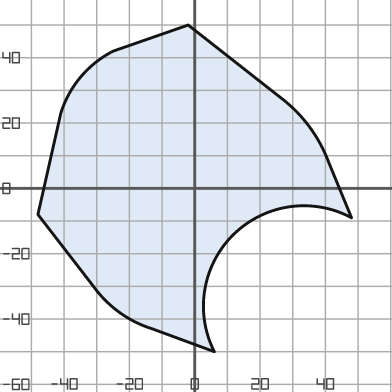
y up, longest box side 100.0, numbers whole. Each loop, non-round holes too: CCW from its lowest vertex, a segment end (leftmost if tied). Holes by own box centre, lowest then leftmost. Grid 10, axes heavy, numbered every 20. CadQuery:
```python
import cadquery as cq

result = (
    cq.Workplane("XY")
    .moveTo(6.0, -50.0)
    .threePointArc((12.0, -14.0), (48.0, -9.0))
    .lineTo(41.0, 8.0)
    .threePointArc((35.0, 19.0), (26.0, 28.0))
    .lineTo(-2.0, 50.0)
    .lineTo(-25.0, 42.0)
    .threePointArc((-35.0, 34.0), (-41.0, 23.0))
    .lineTo(-48.0, -8.0)
    .lineTo(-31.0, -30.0)
    .threePointArc((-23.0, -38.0), (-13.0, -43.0))
    .close()
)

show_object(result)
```